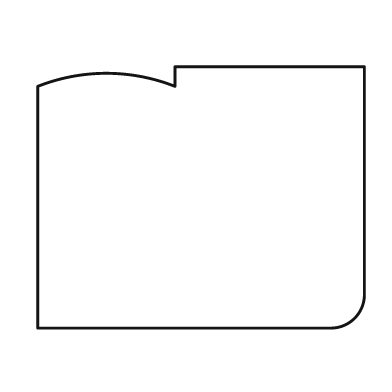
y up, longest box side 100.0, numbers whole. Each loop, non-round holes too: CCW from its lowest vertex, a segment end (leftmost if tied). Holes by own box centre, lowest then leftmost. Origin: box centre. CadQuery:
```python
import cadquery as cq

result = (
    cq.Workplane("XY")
    .moveTo(-50.0, -40.0)
    .lineTo(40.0, -40.0)
    .threePointArc((47.0, -37.0), (50.0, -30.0))
    .lineTo(50.0, 40.0)
    .lineTo(-8.0, 40.0)
    .lineTo(-8.0, 34.0)
    .threePointArc((-29.0, 38.0), (-50.0, 34.0))
    .close()
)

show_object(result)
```